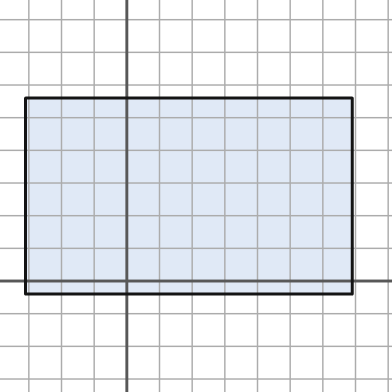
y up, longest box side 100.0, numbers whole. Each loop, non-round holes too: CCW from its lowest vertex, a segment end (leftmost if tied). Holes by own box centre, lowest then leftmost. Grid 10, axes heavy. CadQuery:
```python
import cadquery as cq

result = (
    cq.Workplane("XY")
    .moveTo(-31.0, -4.0)
    .lineTo(69.0, -4.0)
    .lineTo(69.0, 56.0)
    .lineTo(-31.0, 56.0)
    .close()
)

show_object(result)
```